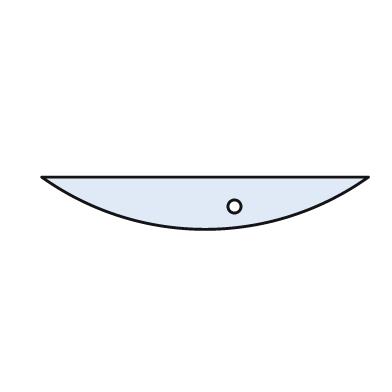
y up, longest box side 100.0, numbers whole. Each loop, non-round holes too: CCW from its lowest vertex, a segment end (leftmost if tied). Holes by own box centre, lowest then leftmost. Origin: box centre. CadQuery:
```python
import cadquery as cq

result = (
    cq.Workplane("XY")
    .moveTo(-50.0, 8.0)
    .threePointArc((0.0, -8.0), (50.0, 8.0))
    .close()
    .moveTo(9.0, -1.0)
    .circle(2.0)
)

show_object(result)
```